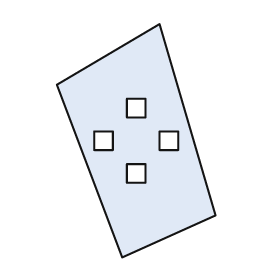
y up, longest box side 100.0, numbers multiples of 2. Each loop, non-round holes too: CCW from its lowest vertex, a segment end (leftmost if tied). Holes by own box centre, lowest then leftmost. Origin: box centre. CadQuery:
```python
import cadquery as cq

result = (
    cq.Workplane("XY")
    .moveTo(-6.0, -50.0)
    .lineTo(34.0, -32.0)
    .lineTo(10.0, 50.0)
    .lineTo(-34.0, 24.0)
    .close()
    .moveTo(-4.0, -18.0)
    .lineTo(4.0, -18.0)
    .lineTo(4.0, -10.0)
    .lineTo(-4.0, -10.0)
    .close()
    .moveTo(-18.0, -4.0)
    .lineTo(-10.0, -4.0)
    .lineTo(-10.0, 4.0)
    .lineTo(-18.0, 4.0)
    .close()
    .moveTo(10.0, -4.0)
    .lineTo(18.0, -4.0)
    .lineTo(18.0, 4.0)
    .lineTo(10.0, 4.0)
    .close()
    .moveTo(-4.0, 10.0)
    .lineTo(4.0, 10.0)
    .lineTo(4.0, 18.0)
    .lineTo(-4.0, 18.0)
    .close()
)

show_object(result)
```